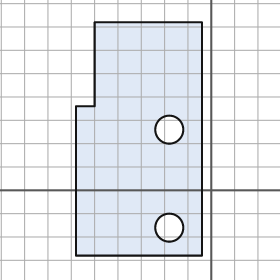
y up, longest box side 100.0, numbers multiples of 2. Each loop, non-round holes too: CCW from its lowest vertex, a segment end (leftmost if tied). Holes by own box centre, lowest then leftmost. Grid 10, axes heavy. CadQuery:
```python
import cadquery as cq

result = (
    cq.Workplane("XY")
    .moveTo(-58.0, -28.0)
    .lineTo(-4.0, -28.0)
    .lineTo(-4.0, 72.0)
    .lineTo(-50.0, 72.0)
    .lineTo(-50.0, 36.0)
    .lineTo(-58.0, 36.0)
    .close()
    .moveTo(-18.0, -16.0)
    .circle(6.0)
    .moveTo(-18.0, 26.0)
    .circle(6.0)
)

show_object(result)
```